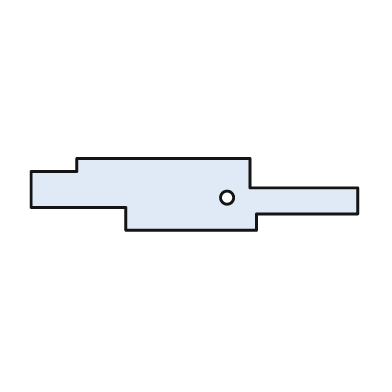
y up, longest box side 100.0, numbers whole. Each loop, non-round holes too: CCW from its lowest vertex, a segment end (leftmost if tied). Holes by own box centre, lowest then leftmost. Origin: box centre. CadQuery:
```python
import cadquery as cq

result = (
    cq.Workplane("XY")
    .moveTo(-21.0, -11.0)
    .lineTo(19.0, -11.0)
    .lineTo(19.0, -6.0)
    .lineTo(50.0, -6.0)
    .lineTo(50.0, 2.0)
    .lineTo(17.0, 2.0)
    .lineTo(17.0, 11.0)
    .lineTo(-36.0, 11.0)
    .lineTo(-36.0, 7.0)
    .lineTo(-50.0, 7.0)
    .lineTo(-50.0, -4.0)
    .lineTo(-21.0, -4.0)
    .close()
    .moveTo(10.0, -1.0)
    .circle(2.0)
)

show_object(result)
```